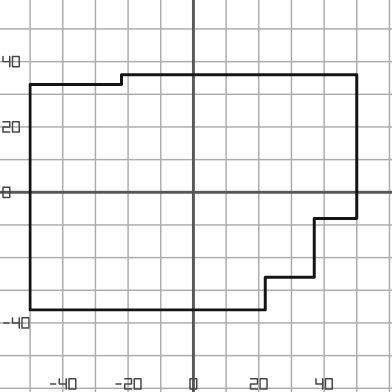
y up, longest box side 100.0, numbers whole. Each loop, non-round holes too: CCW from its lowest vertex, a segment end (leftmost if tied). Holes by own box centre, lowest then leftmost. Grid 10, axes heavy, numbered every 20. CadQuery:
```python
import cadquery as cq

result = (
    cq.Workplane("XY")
    .moveTo(-50.0, -36.0)
    .lineTo(22.0, -36.0)
    .lineTo(22.0, -26.0)
    .lineTo(37.0, -26.0)
    .lineTo(37.0, -8.0)
    .lineTo(50.0, -8.0)
    .lineTo(50.0, 36.0)
    .lineTo(-22.0, 36.0)
    .lineTo(-22.0, 33.0)
    .lineTo(-50.0, 33.0)
    .close()
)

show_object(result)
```